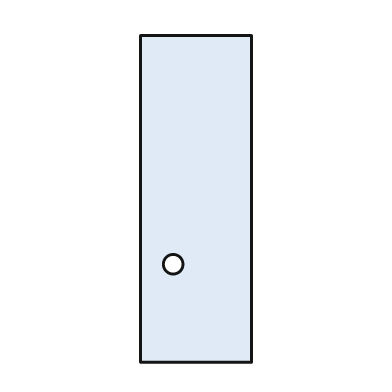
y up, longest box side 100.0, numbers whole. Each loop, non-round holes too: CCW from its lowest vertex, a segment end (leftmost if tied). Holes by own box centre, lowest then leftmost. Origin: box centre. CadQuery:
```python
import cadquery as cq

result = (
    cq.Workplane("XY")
    .moveTo(-17.0, -50.0)
    .lineTo(17.0, -50.0)
    .lineTo(17.0, 50.0)
    .lineTo(-17.0, 50.0)
    .close()
    .moveTo(-7.0, -20.0)
    .circle(3.0)
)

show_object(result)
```